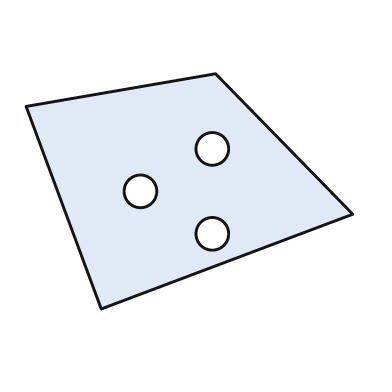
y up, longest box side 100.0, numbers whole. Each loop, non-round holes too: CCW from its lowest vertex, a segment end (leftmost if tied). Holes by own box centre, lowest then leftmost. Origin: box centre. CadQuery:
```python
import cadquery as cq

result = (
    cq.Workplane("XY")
    .moveTo(-27.0, -36.0)
    .lineTo(50.0, -7.0)
    .lineTo(8.0, 36.0)
    .lineTo(-50.0, 26.0)
    .close()
    .moveTo(7.0, -13.0)
    .circle(5.0)
    .moveTo(-15.0, 0.0)
    .circle(5.0)
    .moveTo(7.0, 13.0)
    .circle(5.0)
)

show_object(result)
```